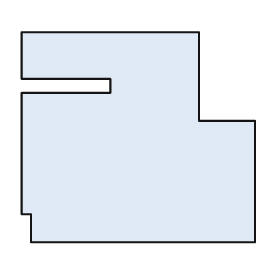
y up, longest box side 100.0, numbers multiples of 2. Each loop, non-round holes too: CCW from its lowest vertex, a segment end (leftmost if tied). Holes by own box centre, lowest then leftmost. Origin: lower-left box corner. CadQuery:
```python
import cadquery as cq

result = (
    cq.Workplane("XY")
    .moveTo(4.0, 0.0)
    .lineTo(100.0, 0.0)
    .lineTo(100.0, 52.0)
    .lineTo(76.0, 52.0)
    .lineTo(76.0, 90.0)
    .lineTo(0.0, 90.0)
    .lineTo(0.0, 70.0)
    .lineTo(38.0, 70.0)
    .lineTo(38.0, 64.0)
    .lineTo(0.0, 64.0)
    .lineTo(0.0, 12.0)
    .lineTo(4.0, 12.0)
    .close()
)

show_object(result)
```